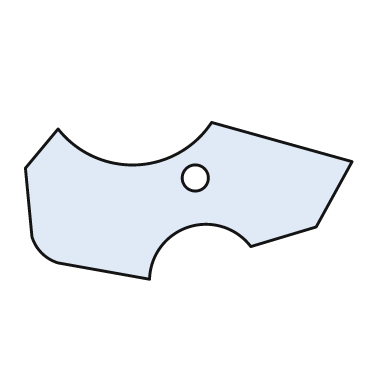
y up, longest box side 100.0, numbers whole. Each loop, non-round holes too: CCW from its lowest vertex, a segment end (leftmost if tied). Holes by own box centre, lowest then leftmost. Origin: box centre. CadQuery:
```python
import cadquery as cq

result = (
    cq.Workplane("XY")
    .moveTo(-12.0, -24.0)
    .threePointArc((0.0, -8.0), (19.0, -14.0))
    .lineTo(39.0, -8.0)
    .lineTo(50.0, 12.0)
    .lineTo(7.0, 24.0)
    .threePointArc((-16.0, 11.0), (-40.0, 22.0))
    .lineTo(-50.0, 10.0)
    .lineTo(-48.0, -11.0)
    .threePointArc((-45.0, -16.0), (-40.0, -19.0))
    .close()
    .moveTo(2.0, 7.0)
    .circle(4.0)
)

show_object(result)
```